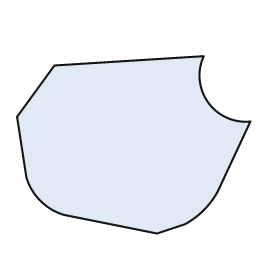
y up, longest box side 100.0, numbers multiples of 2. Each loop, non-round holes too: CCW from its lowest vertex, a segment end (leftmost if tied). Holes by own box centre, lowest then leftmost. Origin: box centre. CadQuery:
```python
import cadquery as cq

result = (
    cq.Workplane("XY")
    .moveTo(10.0, -38.0)
    .lineTo(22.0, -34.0)
    .threePointArc((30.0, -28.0), (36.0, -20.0))
    .lineTo(50.0, 10.0)
    .threePointArc((32.0, 18.0), (30.0, 38.0))
    .lineTo(-34.0, 34.0)
    .lineTo(-50.0, 12.0)
    .lineTo(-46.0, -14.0)
    .threePointArc((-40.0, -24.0), (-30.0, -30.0))
    .close()
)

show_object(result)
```